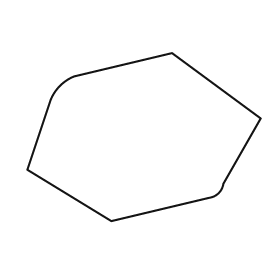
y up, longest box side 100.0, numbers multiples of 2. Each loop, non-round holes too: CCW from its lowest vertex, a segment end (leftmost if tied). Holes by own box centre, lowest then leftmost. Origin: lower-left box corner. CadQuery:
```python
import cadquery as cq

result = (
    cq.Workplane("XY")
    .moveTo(36.0, 0.0)
    .lineTo(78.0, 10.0)
    .threePointArc((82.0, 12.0), (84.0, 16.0))
    .lineTo(100.0, 44.0)
    .lineTo(62.0, 72.0)
    .lineTo(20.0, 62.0)
    .threePointArc((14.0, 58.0), (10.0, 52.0))
    .lineTo(0.0, 22.0)
    .close()
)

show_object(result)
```